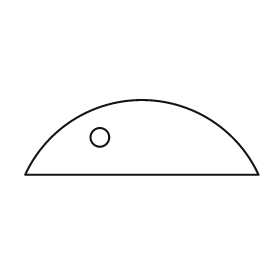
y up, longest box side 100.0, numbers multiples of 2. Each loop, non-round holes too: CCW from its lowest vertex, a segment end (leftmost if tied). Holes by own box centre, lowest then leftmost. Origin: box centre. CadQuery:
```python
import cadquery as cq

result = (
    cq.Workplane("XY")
    .moveTo(-50.0, -16.0)
    .lineTo(50.0, -16.0)
    .threePointArc((0.0, 16.0), (-50.0, -16.0))
    .close()
    .moveTo(-18.0, 0.0)
    .circle(4.0)
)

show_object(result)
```